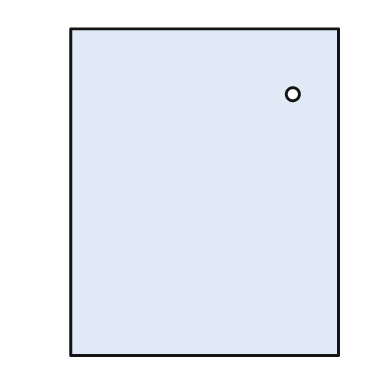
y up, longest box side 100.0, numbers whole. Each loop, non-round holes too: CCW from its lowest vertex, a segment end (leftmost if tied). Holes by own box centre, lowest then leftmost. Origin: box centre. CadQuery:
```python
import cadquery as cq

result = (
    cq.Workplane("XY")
    .moveTo(-41.0, -50.0)
    .lineTo(41.0, -50.0)
    .lineTo(41.0, 50.0)
    .lineTo(-41.0, 50.0)
    .close()
    .moveTo(27.0, 30.0)
    .circle(2.0)
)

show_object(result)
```